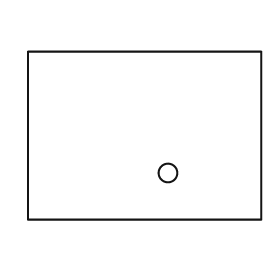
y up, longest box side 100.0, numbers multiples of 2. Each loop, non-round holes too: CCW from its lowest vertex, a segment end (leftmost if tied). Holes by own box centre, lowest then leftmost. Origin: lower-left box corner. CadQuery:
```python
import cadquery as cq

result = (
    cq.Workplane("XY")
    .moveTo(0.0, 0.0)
    .lineTo(100.0, 0.0)
    .lineTo(100.0, 72.0)
    .lineTo(0.0, 72.0)
    .close()
    .moveTo(60.0, 20.0)
    .circle(4.0)
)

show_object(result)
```